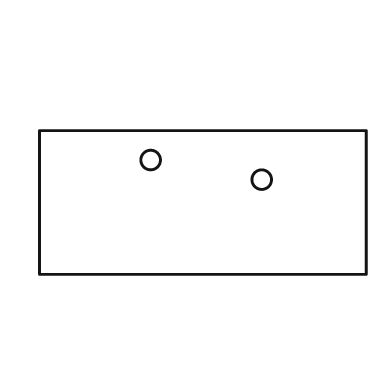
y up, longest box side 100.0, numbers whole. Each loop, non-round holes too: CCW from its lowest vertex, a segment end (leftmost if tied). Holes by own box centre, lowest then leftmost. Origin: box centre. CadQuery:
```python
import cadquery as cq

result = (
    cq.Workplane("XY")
    .moveTo(-50.0, -22.0)
    .lineTo(50.0, -22.0)
    .lineTo(50.0, 22.0)
    .lineTo(-50.0, 22.0)
    .close()
    .moveTo(18.0, 7.0)
    .circle(3.0)
    .moveTo(-16.0, 13.0)
    .circle(3.0)
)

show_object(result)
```